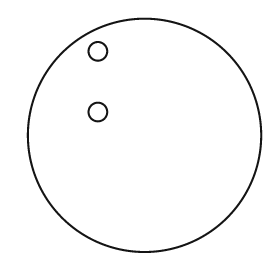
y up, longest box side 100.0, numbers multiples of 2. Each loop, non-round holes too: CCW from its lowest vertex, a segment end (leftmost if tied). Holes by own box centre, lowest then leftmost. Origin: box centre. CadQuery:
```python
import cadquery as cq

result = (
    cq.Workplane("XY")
    .moveTo(0.0, 0.0)
    .circle(50.0)
    .moveTo(-20.0, 10.0)
    .circle(4.0)
    .moveTo(-20.0, 36.0)
    .circle(4.0)
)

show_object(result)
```